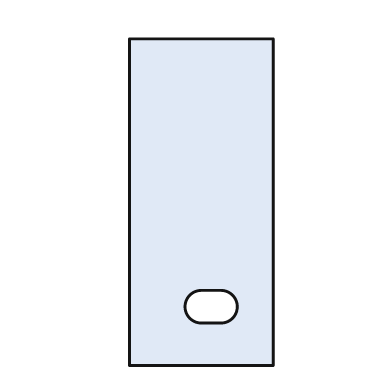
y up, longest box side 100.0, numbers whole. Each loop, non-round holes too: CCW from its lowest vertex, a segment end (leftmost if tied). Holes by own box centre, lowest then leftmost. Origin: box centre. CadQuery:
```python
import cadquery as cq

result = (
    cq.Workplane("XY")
    .moveTo(-22.0, -50.0)
    .lineTo(22.0, -50.0)
    .lineTo(22.0, 50.0)
    .lineTo(-22.0, 50.0)
    .close()
    .moveTo(0.0, -37.0)
    .lineTo(6.0, -37.0)
    .threePointArc((11.0, -32.0), (6.0, -27.0))
    .lineTo(0.0, -27.0)
    .threePointArc((-5.0, -32.0), (0.0, -37.0))
    .close()
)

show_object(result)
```